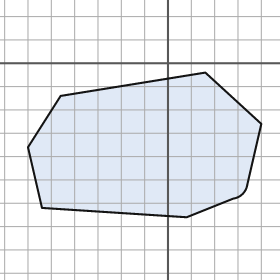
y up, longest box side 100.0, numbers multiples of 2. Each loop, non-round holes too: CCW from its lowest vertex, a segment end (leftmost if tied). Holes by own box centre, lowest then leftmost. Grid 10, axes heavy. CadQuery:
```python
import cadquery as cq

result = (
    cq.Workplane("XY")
    .moveTo(8.0, -66.0)
    .lineTo(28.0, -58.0)
    .threePointArc((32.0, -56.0), (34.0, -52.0))
    .lineTo(40.0, -26.0)
    .lineTo(16.0, -4.0)
    .lineTo(-46.0, -14.0)
    .lineTo(-60.0, -36.0)
    .lineTo(-54.0, -62.0)
    .close()
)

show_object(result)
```